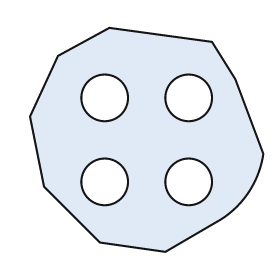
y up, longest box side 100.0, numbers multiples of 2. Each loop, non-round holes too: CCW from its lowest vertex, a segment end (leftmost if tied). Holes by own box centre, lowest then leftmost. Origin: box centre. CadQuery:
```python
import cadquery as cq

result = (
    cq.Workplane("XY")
    .moveTo(8.0, -48.0)
    .lineTo(32.0, -34.0)
    .threePointArc((44.0, -22.0), (50.0, -6.0))
    .lineTo(38.0, 26.0)
    .lineTo(28.0, 42.0)
    .lineTo(-16.0, 48.0)
    .lineTo(-38.0, 36.0)
    .lineTo(-50.0, 10.0)
    .lineTo(-44.0, -20.0)
    .lineTo(-20.0, -44.0)
    .close()
    .moveTo(-18.0, -18.0)
    .circle(10.0)
    .moveTo(18.0, -18.0)
    .circle(10.0)
    .moveTo(-18.0, 18.0)
    .circle(10.0)
    .moveTo(18.0, 18.0)
    .circle(10.0)
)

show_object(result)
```